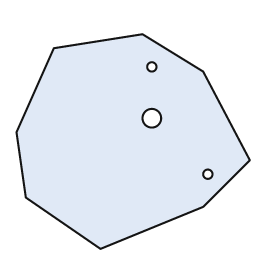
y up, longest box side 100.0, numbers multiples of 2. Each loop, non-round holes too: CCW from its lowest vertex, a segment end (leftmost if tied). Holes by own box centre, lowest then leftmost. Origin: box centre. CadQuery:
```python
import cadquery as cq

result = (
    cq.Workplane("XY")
    .moveTo(-14.0, -46.0)
    .lineTo(30.0, -28.0)
    .lineTo(50.0, -8.0)
    .lineTo(30.0, 30.0)
    .lineTo(4.0, 46.0)
    .lineTo(-34.0, 40.0)
    .lineTo(-50.0, 4.0)
    .lineTo(-46.0, -24.0)
    .close()
    .moveTo(32.0, -14.0)
    .circle(2.0)
    .moveTo(8.0, 10.0)
    .circle(4.0)
    .moveTo(8.0, 32.0)
    .circle(2.0)
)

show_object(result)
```